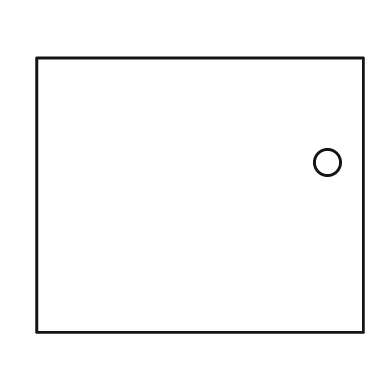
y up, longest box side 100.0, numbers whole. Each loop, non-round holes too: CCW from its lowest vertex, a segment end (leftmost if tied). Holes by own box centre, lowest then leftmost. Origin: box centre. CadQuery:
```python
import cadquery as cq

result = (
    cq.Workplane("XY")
    .moveTo(-50.0, -42.0)
    .lineTo(50.0, -42.0)
    .lineTo(50.0, 42.0)
    .lineTo(-50.0, 42.0)
    .close()
    .moveTo(39.0, 10.0)
    .circle(4.0)
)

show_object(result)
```